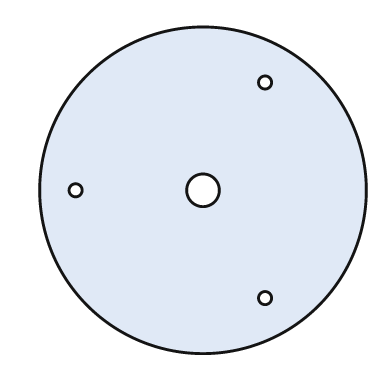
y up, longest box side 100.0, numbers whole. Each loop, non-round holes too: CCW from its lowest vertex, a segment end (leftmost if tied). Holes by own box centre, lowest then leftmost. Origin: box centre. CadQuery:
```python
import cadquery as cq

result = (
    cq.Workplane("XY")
    .moveTo(0.0, 0.0)
    .circle(50.0)
    .moveTo(19.0, -33.0)
    .circle(2.0)
    .moveTo(-39.0, 0.0)
    .circle(2.0)
    .moveTo(0.0, 0.0)
    .circle(5.0)
    .moveTo(19.0, 33.0)
    .circle(2.0)
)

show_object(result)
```